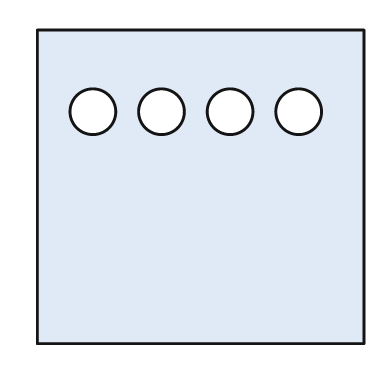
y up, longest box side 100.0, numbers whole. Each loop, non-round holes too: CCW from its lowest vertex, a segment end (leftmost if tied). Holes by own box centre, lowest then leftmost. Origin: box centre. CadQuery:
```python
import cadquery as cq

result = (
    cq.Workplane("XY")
    .moveTo(-50.0, -48.0)
    .lineTo(50.0, -48.0)
    .lineTo(50.0, 48.0)
    .lineTo(-50.0, 48.0)
    .close()
    .moveTo(-33.0, 23.0)
    .circle(7.0)
    .moveTo(-12.0, 23.0)
    .circle(7.0)
    .moveTo(9.0, 23.0)
    .circle(7.0)
    .moveTo(30.0, 23.0)
    .circle(7.0)
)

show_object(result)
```